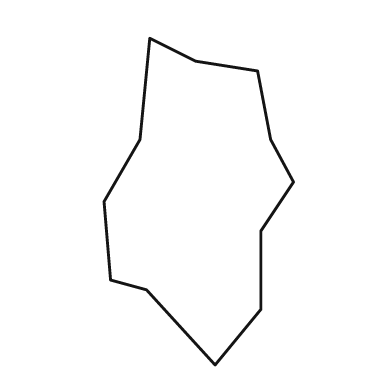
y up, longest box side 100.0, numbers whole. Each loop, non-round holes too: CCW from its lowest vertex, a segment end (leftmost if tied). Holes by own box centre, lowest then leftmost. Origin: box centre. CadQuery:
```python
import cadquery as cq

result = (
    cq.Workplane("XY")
    .moveTo(5.0, -50.0)
    .lineTo(19.0, -33.0)
    .lineTo(19.0, -9.0)
    .lineTo(29.0, 6.0)
    .lineTo(22.0, 19.0)
    .lineTo(18.0, 40.0)
    .lineTo(-1.0, 43.0)
    .lineTo(-15.0, 50.0)
    .lineTo(-18.0, 19.0)
    .lineTo(-29.0, 0.0)
    .lineTo(-27.0, -24.0)
    .lineTo(-16.0, -27.0)
    .close()
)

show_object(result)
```